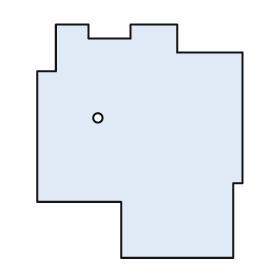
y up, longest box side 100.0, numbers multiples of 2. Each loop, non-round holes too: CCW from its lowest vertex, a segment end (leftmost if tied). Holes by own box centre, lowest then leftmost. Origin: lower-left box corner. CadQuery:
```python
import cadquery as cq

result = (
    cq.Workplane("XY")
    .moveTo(36.0, 0.0)
    .lineTo(84.0, 0.0)
    .lineTo(84.0, 32.0)
    .lineTo(88.0, 32.0)
    .lineTo(88.0, 88.0)
    .lineTo(60.0, 88.0)
    .lineTo(60.0, 100.0)
    .lineTo(40.0, 100.0)
    .lineTo(40.0, 94.0)
    .lineTo(22.0, 94.0)
    .lineTo(22.0, 100.0)
    .lineTo(8.0, 100.0)
    .lineTo(8.0, 80.0)
    .lineTo(0.0, 80.0)
    .lineTo(0.0, 24.0)
    .lineTo(36.0, 24.0)
    .close()
    .moveTo(26.0, 60.0)
    .circle(2.0)
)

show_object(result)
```